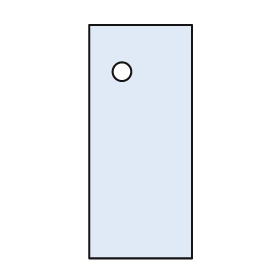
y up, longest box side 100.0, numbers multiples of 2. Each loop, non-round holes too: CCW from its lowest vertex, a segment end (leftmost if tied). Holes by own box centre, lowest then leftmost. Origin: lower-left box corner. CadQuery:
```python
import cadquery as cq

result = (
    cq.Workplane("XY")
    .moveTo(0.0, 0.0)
    .lineTo(44.0, 0.0)
    .lineTo(44.0, 100.0)
    .lineTo(0.0, 100.0)
    .close()
    .moveTo(14.0, 80.0)
    .circle(4.0)
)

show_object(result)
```